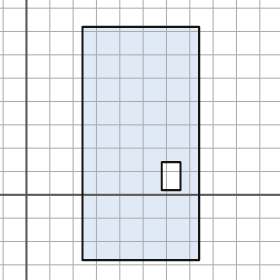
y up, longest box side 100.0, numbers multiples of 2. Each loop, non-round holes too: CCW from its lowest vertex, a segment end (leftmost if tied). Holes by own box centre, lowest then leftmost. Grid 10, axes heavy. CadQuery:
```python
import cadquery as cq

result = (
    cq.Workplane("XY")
    .moveTo(24.0, -28.0)
    .lineTo(74.0, -28.0)
    .lineTo(74.0, 72.0)
    .lineTo(24.0, 72.0)
    .close()
    .moveTo(58.0, 2.0)
    .lineTo(66.0, 2.0)
    .lineTo(66.0, 14.0)
    .lineTo(58.0, 14.0)
    .close()
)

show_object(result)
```